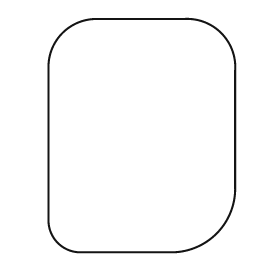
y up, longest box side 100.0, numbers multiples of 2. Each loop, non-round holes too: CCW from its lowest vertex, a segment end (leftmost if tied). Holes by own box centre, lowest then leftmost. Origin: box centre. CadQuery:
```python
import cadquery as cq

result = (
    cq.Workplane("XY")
    .moveTo(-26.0, -50.0)
    .lineTo(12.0, -50.0)
    .threePointArc((32.0, -42.0), (40.0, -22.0))
    .lineTo(40.0, 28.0)
    .threePointArc((34.0, 44.0), (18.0, 50.0))
    .lineTo(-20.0, 50.0)
    .threePointArc((-34.0, 44.0), (-40.0, 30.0))
    .lineTo(-40.0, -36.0)
    .threePointArc((-36.0, -46.0), (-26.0, -50.0))
    .close()
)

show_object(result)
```